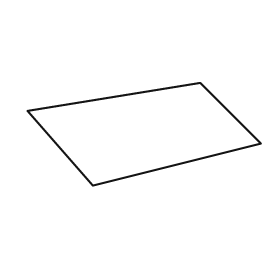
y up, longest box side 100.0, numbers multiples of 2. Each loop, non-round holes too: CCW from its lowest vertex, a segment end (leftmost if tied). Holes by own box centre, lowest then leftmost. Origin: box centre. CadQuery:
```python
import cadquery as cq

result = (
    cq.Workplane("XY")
    .moveTo(-22.0, -22.0)
    .lineTo(50.0, -4.0)
    .lineTo(24.0, 22.0)
    .lineTo(-50.0, 10.0)
    .close()
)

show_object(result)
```